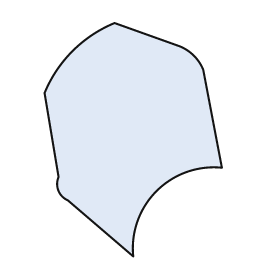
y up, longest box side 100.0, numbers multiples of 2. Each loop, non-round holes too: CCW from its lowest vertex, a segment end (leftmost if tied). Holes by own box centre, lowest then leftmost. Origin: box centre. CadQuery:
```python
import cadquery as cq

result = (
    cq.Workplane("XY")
    .moveTo(0.0, -50.0)
    .threePointArc((10.0, -22.0), (38.0, -12.0))
    .lineTo(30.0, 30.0)
    .threePointArc((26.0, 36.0), (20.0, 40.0))
    .lineTo(-8.0, 50.0)
    .threePointArc((-26.0, 38.0), (-38.0, 20.0))
    .lineTo(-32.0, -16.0)
    .threePointArc((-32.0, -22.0), (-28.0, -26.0))
    .close()
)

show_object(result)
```